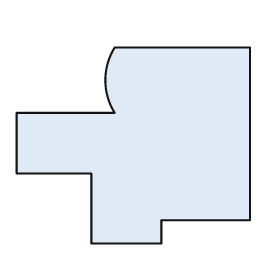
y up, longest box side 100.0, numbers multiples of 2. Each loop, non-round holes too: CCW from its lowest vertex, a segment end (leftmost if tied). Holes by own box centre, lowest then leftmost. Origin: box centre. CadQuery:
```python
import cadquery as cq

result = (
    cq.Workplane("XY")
    .moveTo(-18.0, -42.0)
    .lineTo(12.0, -42.0)
    .lineTo(12.0, -32.0)
    .lineTo(50.0, -32.0)
    .lineTo(50.0, 42.0)
    .lineTo(-8.0, 42.0)
    .threePointArc((-12.0, 28.0), (-8.0, 14.0))
    .lineTo(-50.0, 14.0)
    .lineTo(-50.0, -12.0)
    .lineTo(-18.0, -12.0)
    .close()
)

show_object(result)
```